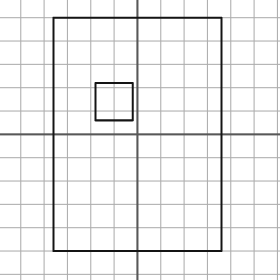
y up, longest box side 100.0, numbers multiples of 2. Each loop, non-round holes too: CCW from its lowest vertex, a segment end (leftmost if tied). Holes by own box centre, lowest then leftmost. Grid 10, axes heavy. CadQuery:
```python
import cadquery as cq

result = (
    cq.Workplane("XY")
    .moveTo(-36.0, -50.0)
    .lineTo(36.0, -50.0)
    .lineTo(36.0, 50.0)
    .lineTo(-36.0, 50.0)
    .close()
    .moveTo(-18.0, 6.0)
    .lineTo(-2.0, 6.0)
    .lineTo(-2.0, 22.0)
    .lineTo(-18.0, 22.0)
    .close()
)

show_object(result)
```